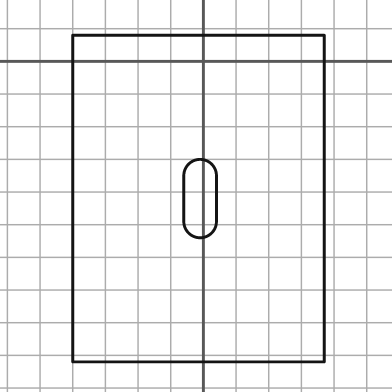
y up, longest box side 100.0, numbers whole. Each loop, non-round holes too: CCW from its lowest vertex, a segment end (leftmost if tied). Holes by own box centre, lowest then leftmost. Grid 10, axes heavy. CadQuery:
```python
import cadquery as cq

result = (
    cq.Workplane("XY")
    .moveTo(-40.0, -92.0)
    .lineTo(37.0, -92.0)
    .lineTo(37.0, 8.0)
    .lineTo(-40.0, 8.0)
    .close()
    .moveTo(-6.0, -49.0)
    .threePointArc((-1.0, -54.0), (4.0, -49.0))
    .lineTo(4.0, -35.0)
    .threePointArc((-1.0, -30.0), (-6.0, -35.0))
    .close()
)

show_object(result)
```